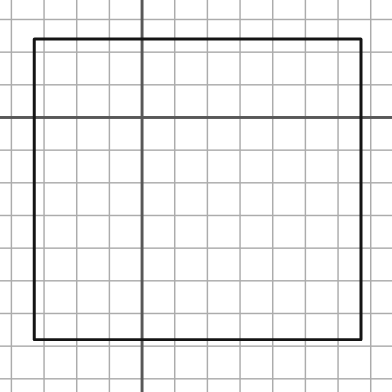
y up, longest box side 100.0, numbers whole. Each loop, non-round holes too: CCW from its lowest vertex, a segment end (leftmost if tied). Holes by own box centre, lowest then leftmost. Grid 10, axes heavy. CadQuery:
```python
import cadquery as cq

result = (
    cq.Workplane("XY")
    .moveTo(-33.0, -68.0)
    .lineTo(67.0, -68.0)
    .lineTo(67.0, 24.0)
    .lineTo(-33.0, 24.0)
    .close()
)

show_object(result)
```